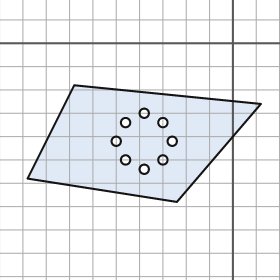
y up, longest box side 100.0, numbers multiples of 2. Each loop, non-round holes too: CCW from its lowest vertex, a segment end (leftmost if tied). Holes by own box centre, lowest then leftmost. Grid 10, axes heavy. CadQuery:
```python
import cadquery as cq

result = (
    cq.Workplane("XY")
    .moveTo(-24.0, -68.0)
    .lineTo(12.0, -26.0)
    .lineTo(-68.0, -18.0)
    .lineTo(-88.0, -58.0)
    .close()
    .moveTo(-38.0, -54.0)
    .circle(2.0)
    .moveTo(-46.0, -50.0)
    .circle(2.0)
    .moveTo(-30.0, -50.0)
    .circle(2.0)
    .moveTo(-50.0, -42.0)
    .circle(2.0)
    .moveTo(-26.0, -42.0)
    .circle(2.0)
    .moveTo(-46.0, -34.0)
    .circle(2.0)
    .moveTo(-30.0, -34.0)
    .circle(2.0)
    .moveTo(-38.0, -30.0)
    .circle(2.0)
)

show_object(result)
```